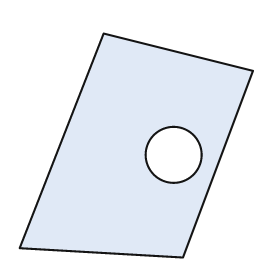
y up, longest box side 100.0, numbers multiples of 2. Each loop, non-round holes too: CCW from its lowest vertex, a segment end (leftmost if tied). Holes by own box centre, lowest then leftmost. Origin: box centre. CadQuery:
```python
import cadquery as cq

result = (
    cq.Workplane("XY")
    .moveTo(20.0, -48.0)
    .lineTo(50.0, 32.0)
    .lineTo(-14.0, 48.0)
    .lineTo(-50.0, -44.0)
    .close()
    .moveTo(16.0, -4.0)
    .circle(12.0)
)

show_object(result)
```